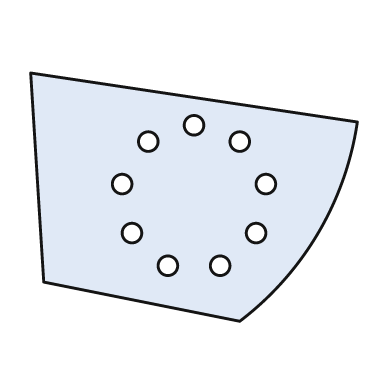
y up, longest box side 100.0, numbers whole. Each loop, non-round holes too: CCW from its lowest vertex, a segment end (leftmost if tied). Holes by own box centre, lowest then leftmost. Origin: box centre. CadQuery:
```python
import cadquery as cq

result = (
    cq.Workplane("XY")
    .moveTo(14.0, -38.0)
    .threePointArc((38.0, -11.0), (50.0, 23.0))
    .lineTo(-50.0, 38.0)
    .lineTo(-46.0, -26.0)
    .close()
    .moveTo(-8.0, -21.0)
    .circle(3.0)
    .moveTo(8.0, -21.0)
    .circle(3.0)
    .moveTo(-19.0, -11.0)
    .circle(3.0)
    .moveTo(19.0, -11.0)
    .circle(3.0)
    .moveTo(-22.0, 4.0)
    .circle(3.0)
    .moveTo(22.0, 4.0)
    .circle(3.0)
    .moveTo(-14.0, 17.0)
    .circle(3.0)
    .moveTo(14.0, 17.0)
    .circle(3.0)
    .moveTo(0.0, 22.0)
    .circle(3.0)
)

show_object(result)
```